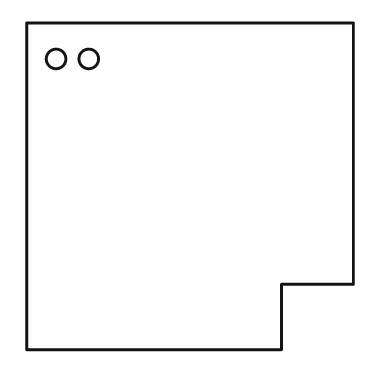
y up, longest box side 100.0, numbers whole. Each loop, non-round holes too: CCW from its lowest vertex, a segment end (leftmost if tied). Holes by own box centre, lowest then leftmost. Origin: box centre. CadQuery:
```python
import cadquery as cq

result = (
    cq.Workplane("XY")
    .moveTo(-50.0, -50.0)
    .lineTo(28.0, -50.0)
    .lineTo(28.0, -30.0)
    .lineTo(50.0, -30.0)
    .lineTo(50.0, 50.0)
    .lineTo(-50.0, 50.0)
    .close()
    .moveTo(-41.0, 39.0)
    .circle(3.0)
    .moveTo(-31.0, 39.0)
    .circle(3.0)
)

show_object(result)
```